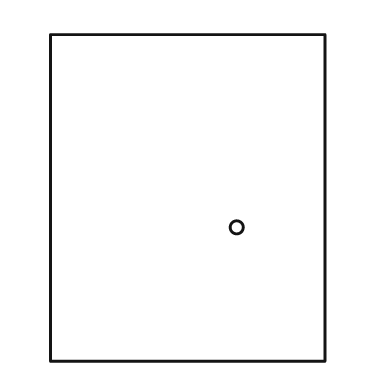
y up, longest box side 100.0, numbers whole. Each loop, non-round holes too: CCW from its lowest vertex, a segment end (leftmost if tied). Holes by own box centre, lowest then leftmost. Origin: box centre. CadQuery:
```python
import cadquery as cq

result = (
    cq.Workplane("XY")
    .moveTo(-42.0, -50.0)
    .lineTo(42.0, -50.0)
    .lineTo(42.0, 50.0)
    .lineTo(-42.0, 50.0)
    .close()
    .moveTo(15.0, -9.0)
    .circle(2.0)
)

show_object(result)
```